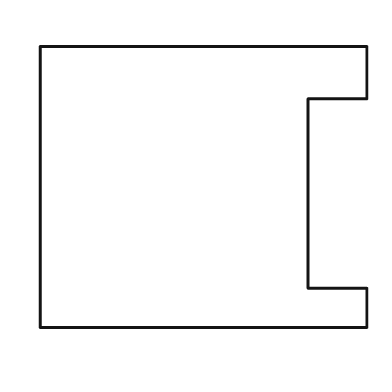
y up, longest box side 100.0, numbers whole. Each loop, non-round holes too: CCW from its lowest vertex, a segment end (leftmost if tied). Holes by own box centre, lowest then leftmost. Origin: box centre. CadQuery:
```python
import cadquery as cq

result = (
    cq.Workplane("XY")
    .moveTo(-50.0, -43.0)
    .lineTo(50.0, -43.0)
    .lineTo(50.0, -31.0)
    .lineTo(32.0, -31.0)
    .lineTo(32.0, 27.0)
    .lineTo(50.0, 27.0)
    .lineTo(50.0, 43.0)
    .lineTo(-50.0, 43.0)
    .close()
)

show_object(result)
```